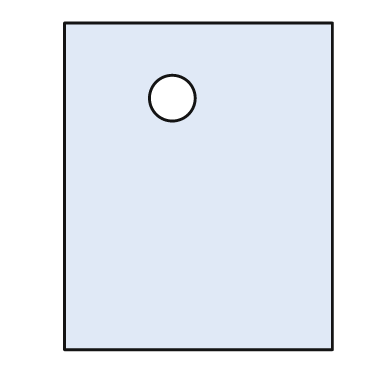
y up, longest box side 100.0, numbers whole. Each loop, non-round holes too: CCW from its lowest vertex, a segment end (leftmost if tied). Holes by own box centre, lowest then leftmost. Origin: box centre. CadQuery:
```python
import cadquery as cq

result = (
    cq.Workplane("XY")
    .moveTo(-41.0, -50.0)
    .lineTo(41.0, -50.0)
    .lineTo(41.0, 50.0)
    .lineTo(-41.0, 50.0)
    .close()
    .moveTo(-8.0, 27.0)
    .circle(7.0)
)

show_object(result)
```